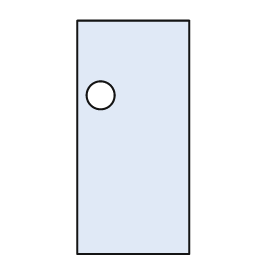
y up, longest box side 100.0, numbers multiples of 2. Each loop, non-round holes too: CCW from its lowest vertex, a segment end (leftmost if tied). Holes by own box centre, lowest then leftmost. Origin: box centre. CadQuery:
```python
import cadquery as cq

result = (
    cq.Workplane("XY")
    .moveTo(-24.0, -50.0)
    .lineTo(24.0, -50.0)
    .lineTo(24.0, 50.0)
    .lineTo(-24.0, 50.0)
    .close()
    .moveTo(-14.0, 18.0)
    .circle(6.0)
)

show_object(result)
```